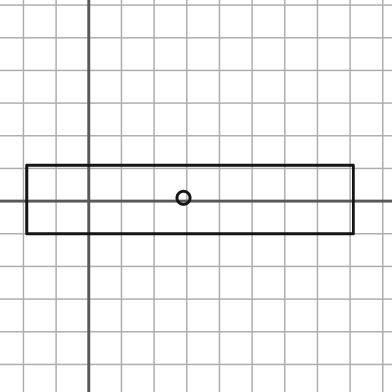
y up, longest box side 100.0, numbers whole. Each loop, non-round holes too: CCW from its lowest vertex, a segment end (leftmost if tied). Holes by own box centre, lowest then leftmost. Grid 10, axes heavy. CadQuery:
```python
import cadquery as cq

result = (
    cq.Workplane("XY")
    .moveTo(-19.0, -10.0)
    .lineTo(81.0, -10.0)
    .lineTo(81.0, 11.0)
    .lineTo(-19.0, 11.0)
    .close()
    .moveTo(29.0, 1.0)
    .circle(2.0)
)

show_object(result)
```